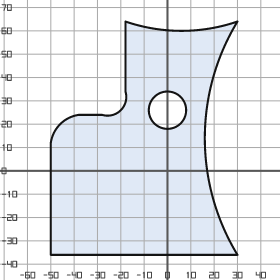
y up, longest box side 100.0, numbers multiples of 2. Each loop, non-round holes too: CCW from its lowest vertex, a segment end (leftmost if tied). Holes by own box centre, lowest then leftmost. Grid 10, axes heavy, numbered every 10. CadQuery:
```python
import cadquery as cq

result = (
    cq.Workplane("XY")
    .moveTo(-50.0, -36.0)
    .lineTo(30.0, -36.0)
    .threePointArc((16.0, 14.0), (30.0, 64.0))
    .threePointArc((6.0, 60.0), (-18.0, 64.0))
    .lineTo(-18.0, 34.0)
    .threePointArc((-20.0, 26.0), (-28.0, 24.0))
    .lineTo(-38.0, 24.0)
    .threePointArc((-46.0, 20.0), (-50.0, 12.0))
    .close()
    .moveTo(0.0, 26.0)
    .circle(8.0)
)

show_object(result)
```